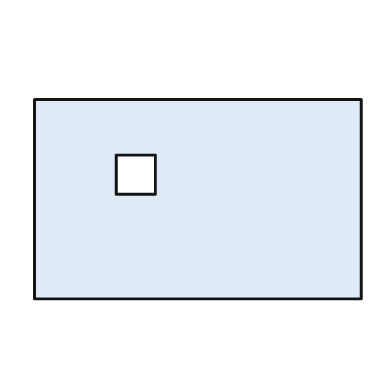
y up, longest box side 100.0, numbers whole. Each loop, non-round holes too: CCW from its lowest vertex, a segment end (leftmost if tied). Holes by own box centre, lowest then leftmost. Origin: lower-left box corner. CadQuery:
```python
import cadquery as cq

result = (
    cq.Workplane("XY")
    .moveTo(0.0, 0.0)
    .lineTo(100.0, 0.0)
    .lineTo(100.0, 61.0)
    .lineTo(0.0, 61.0)
    .close()
    .moveTo(25.0, 32.0)
    .lineTo(37.0, 32.0)
    .lineTo(37.0, 44.0)
    .lineTo(25.0, 44.0)
    .close()
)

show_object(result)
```